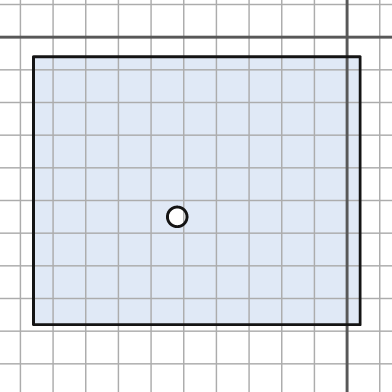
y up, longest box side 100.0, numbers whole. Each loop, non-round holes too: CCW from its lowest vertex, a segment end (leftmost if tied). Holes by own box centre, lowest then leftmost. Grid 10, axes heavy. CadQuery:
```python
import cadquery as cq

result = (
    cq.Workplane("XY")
    .moveTo(-96.0, -88.0)
    .lineTo(4.0, -88.0)
    .lineTo(4.0, -6.0)
    .lineTo(-96.0, -6.0)
    .close()
    .moveTo(-52.0, -55.0)
    .circle(3.0)
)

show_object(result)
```